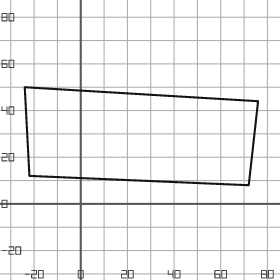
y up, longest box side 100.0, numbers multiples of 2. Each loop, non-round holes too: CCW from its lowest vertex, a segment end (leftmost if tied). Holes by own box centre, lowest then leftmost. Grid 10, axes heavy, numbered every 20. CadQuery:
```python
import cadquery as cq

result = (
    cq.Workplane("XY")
    .moveTo(72.0, 8.0)
    .lineTo(76.0, 44.0)
    .lineTo(-24.0, 50.0)
    .lineTo(-22.0, 12.0)
    .close()
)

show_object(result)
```